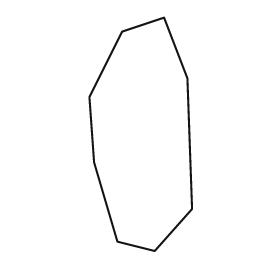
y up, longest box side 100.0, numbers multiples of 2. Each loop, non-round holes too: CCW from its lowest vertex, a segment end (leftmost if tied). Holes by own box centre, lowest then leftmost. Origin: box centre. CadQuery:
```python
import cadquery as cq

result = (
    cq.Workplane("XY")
    .moveTo(6.0, -50.0)
    .lineTo(22.0, -32.0)
    .lineTo(20.0, 24.0)
    .lineTo(10.0, 50.0)
    .lineTo(-8.0, 44.0)
    .lineTo(-22.0, 16.0)
    .lineTo(-20.0, -12.0)
    .lineTo(-10.0, -46.0)
    .close()
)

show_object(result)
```